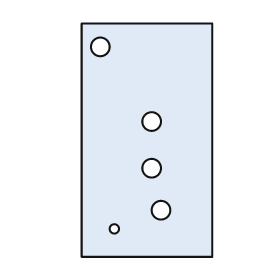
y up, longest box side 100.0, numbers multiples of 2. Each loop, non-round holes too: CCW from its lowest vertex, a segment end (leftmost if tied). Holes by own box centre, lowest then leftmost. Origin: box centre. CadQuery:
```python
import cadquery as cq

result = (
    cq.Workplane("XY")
    .moveTo(-28.0, -50.0)
    .lineTo(28.0, -50.0)
    .lineTo(28.0, 50.0)
    .lineTo(-28.0, 50.0)
    .close()
    .moveTo(-14.0, -38.0)
    .circle(2.0)
    .moveTo(6.0, -30.0)
    .circle(4.0)
    .moveTo(2.0, -12.0)
    .circle(4.0)
    .moveTo(2.0, 8.0)
    .circle(4.0)
    .moveTo(-20.0, 40.0)
    .circle(4.0)
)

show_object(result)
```